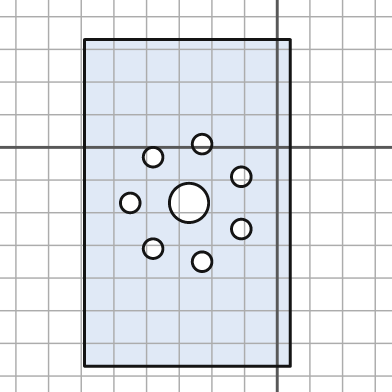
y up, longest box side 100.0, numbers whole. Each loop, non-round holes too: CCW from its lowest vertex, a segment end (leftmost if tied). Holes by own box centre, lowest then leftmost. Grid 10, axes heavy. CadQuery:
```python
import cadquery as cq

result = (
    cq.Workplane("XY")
    .moveTo(-59.0, -67.0)
    .lineTo(4.0, -67.0)
    .lineTo(4.0, 33.0)
    .lineTo(-59.0, 33.0)
    .close()
    .moveTo(-23.0, -35.0)
    .circle(3.0)
    .moveTo(-38.0, -31.0)
    .circle(3.0)
    .moveTo(-11.0, -25.0)
    .circle(3.0)
    .moveTo(-45.0, -17.0)
    .circle(3.0)
    .moveTo(-27.0, -17.0)
    .circle(6.0)
    .moveTo(-11.0, -9.0)
    .circle(3.0)
    .moveTo(-38.0, -3.0)
    .circle(3.0)
    .moveTo(-23.0, 1.0)
    .circle(3.0)
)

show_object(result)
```